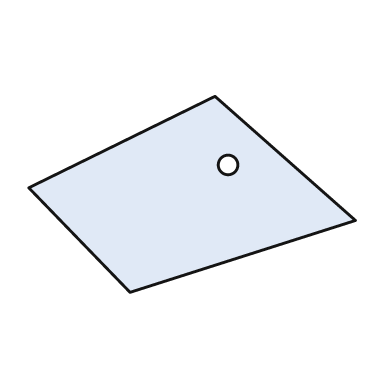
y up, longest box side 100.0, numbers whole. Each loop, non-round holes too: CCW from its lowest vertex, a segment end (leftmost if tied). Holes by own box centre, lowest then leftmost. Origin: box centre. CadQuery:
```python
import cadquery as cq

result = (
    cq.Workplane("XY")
    .moveTo(-19.0, -30.0)
    .lineTo(50.0, -8.0)
    .lineTo(7.0, 30.0)
    .lineTo(-50.0, 2.0)
    .close()
    .moveTo(11.0, 9.0)
    .circle(3.0)
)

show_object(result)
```